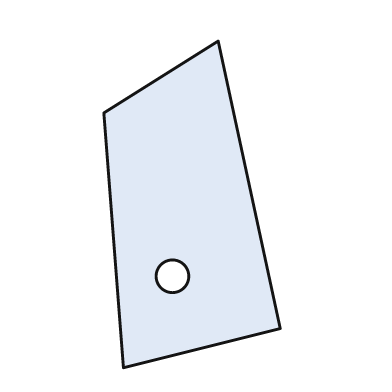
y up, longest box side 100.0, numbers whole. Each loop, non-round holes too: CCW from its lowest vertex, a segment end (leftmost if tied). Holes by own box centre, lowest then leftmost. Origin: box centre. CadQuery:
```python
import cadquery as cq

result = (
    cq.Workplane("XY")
    .moveTo(-21.0, -50.0)
    .lineTo(27.0, -38.0)
    .lineTo(8.0, 50.0)
    .lineTo(-27.0, 28.0)
    .close()
    .moveTo(-6.0, -22.0)
    .circle(5.0)
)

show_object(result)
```